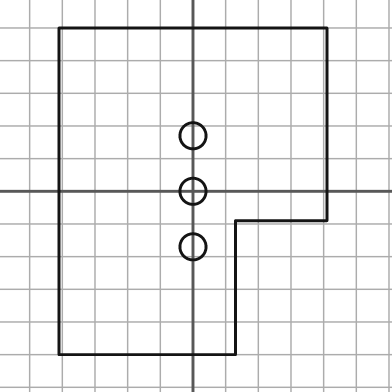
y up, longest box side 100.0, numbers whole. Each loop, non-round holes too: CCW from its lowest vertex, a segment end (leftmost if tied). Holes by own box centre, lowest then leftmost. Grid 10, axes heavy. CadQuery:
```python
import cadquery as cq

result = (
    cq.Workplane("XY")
    .moveTo(-41.0, -50.0)
    .lineTo(13.0, -50.0)
    .lineTo(13.0, -9.0)
    .lineTo(41.0, -9.0)
    .lineTo(41.0, 50.0)
    .lineTo(-41.0, 50.0)
    .close()
    .moveTo(0.0, -17.0)
    .circle(4.0)
    .moveTo(0.0, 0.0)
    .circle(4.0)
    .moveTo(0.0, 17.0)
    .circle(4.0)
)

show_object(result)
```